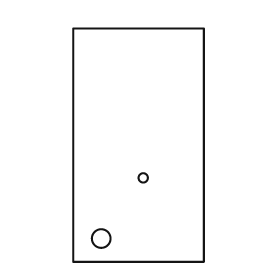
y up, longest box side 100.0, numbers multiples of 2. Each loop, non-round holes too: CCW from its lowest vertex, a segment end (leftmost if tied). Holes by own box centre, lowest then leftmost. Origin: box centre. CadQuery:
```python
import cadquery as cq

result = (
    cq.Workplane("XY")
    .moveTo(-28.0, -50.0)
    .lineTo(28.0, -50.0)
    .lineTo(28.0, 50.0)
    .lineTo(-28.0, 50.0)
    .close()
    .moveTo(-16.0, -40.0)
    .circle(4.0)
    .moveTo(2.0, -14.0)
    .circle(2.0)
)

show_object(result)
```